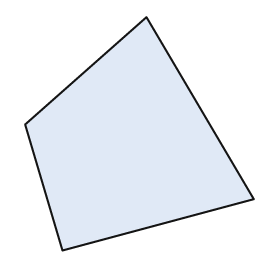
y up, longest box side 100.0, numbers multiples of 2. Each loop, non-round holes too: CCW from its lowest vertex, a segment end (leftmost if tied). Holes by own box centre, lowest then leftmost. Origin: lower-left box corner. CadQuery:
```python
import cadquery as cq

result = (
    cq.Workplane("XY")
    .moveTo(16.0, 0.0)
    .lineTo(98.0, 22.0)
    .lineTo(52.0, 100.0)
    .lineTo(0.0, 54.0)
    .close()
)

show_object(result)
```